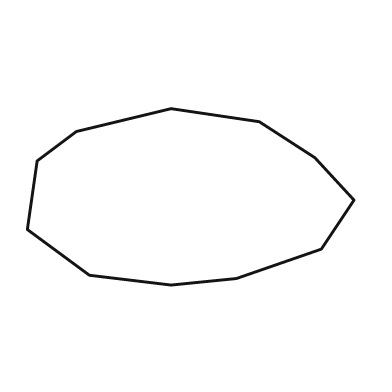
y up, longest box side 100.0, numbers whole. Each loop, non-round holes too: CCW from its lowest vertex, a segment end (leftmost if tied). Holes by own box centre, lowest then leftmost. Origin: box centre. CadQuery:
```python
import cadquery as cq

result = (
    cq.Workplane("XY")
    .moveTo(-6.0, -27.0)
    .lineTo(14.0, -25.0)
    .lineTo(40.0, -16.0)
    .lineTo(50.0, -1.0)
    .lineTo(38.0, 12.0)
    .lineTo(21.0, 23.0)
    .lineTo(-6.0, 27.0)
    .lineTo(-35.0, 20.0)
    .lineTo(-47.0, 11.0)
    .lineTo(-50.0, -10.0)
    .lineTo(-31.0, -24.0)
    .close()
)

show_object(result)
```